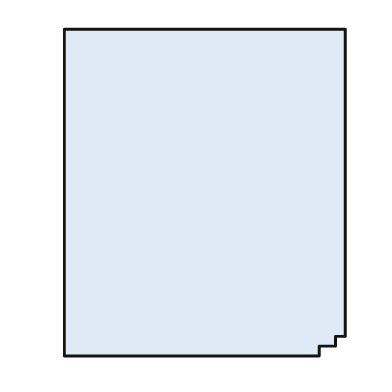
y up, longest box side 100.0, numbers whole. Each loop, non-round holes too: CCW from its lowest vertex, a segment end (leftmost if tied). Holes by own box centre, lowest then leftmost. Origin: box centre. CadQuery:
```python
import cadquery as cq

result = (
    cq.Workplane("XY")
    .moveTo(-43.0, -50.0)
    .lineTo(35.0, -50.0)
    .lineTo(35.0, -47.0)
    .lineTo(40.0, -47.0)
    .lineTo(40.0, -44.0)
    .lineTo(43.0, -44.0)
    .lineTo(43.0, 50.0)
    .lineTo(-43.0, 50.0)
    .close()
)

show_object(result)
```